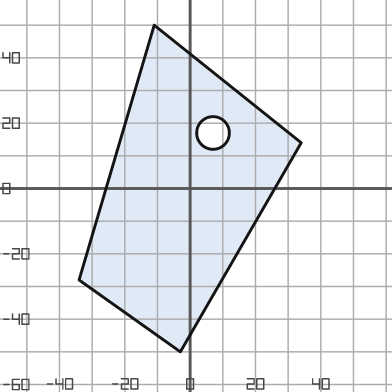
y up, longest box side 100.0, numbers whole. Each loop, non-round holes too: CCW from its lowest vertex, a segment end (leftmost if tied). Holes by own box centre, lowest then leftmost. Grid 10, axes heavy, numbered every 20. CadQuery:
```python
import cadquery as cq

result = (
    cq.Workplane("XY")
    .moveTo(-3.0, -50.0)
    .lineTo(34.0, 14.0)
    .lineTo(-11.0, 50.0)
    .lineTo(-34.0, -28.0)
    .close()
    .moveTo(7.0, 17.0)
    .circle(5.0)
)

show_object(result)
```